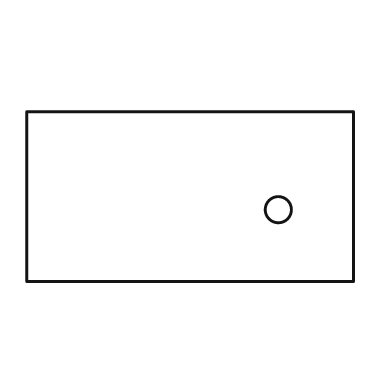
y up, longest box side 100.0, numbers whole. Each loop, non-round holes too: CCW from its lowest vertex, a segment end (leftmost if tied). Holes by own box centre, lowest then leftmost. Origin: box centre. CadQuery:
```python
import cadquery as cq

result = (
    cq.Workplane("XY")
    .moveTo(-50.0, -26.0)
    .lineTo(50.0, -26.0)
    .lineTo(50.0, 26.0)
    .lineTo(-50.0, 26.0)
    .close()
    .moveTo(27.0, -4.0)
    .circle(4.0)
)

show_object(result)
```